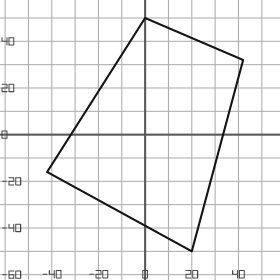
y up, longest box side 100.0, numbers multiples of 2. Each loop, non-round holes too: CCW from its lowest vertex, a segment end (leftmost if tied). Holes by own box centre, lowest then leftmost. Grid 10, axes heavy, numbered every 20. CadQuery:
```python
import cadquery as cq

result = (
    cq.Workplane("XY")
    .moveTo(20.0, -50.0)
    .lineTo(42.0, 32.0)
    .lineTo(0.0, 50.0)
    .lineTo(-42.0, -16.0)
    .close()
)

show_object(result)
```